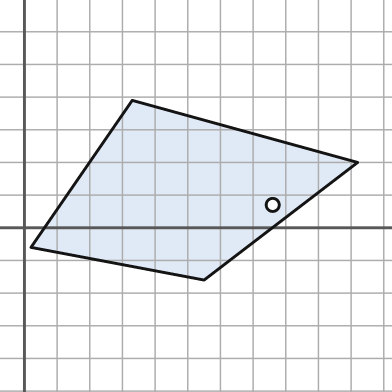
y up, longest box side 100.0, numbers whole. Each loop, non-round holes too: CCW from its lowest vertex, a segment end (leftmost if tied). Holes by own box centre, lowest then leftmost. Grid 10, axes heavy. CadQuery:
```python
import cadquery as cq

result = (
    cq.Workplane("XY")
    .moveTo(55.0, -16.0)
    .lineTo(102.0, 20.0)
    .lineTo(33.0, 39.0)
    .lineTo(2.0, -6.0)
    .close()
    .moveTo(76.0, 7.0)
    .circle(2.0)
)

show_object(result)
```